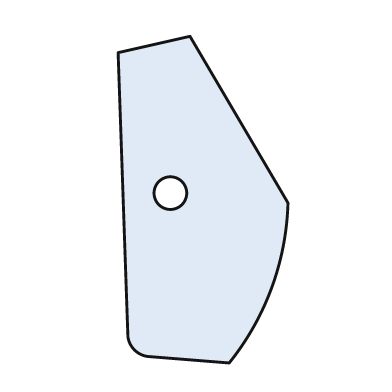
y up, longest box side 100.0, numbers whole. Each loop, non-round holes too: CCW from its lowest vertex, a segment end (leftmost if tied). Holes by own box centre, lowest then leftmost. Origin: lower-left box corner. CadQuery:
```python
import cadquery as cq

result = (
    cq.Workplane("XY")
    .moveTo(34.0, 0.0)
    .threePointArc((47.0, 23.0), (52.0, 49.0))
    .lineTo(22.0, 100.0)
    .lineTo(0.0, 95.0)
    .lineTo(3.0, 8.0)
    .threePointArc((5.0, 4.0), (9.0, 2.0))
    .close()
    .moveTo(16.0, 52.0)
    .circle(5.0)
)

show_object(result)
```